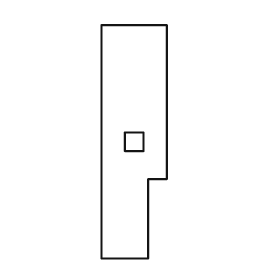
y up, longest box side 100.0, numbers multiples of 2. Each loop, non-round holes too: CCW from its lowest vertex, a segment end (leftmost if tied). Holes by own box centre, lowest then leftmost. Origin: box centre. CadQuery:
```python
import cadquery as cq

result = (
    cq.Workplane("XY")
    .moveTo(-14.0, -50.0)
    .lineTo(6.0, -50.0)
    .lineTo(6.0, -16.0)
    .lineTo(14.0, -16.0)
    .lineTo(14.0, 50.0)
    .lineTo(-14.0, 50.0)
    .close()
    .moveTo(-4.0, -4.0)
    .lineTo(4.0, -4.0)
    .lineTo(4.0, 4.0)
    .lineTo(-4.0, 4.0)
    .close()
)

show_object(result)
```